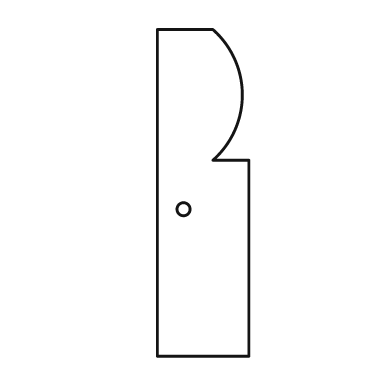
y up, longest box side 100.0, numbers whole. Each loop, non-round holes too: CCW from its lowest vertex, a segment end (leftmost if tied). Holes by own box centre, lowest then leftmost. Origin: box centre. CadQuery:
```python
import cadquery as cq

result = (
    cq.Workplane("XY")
    .moveTo(-14.0, -50.0)
    .lineTo(14.0, -50.0)
    .lineTo(14.0, 10.0)
    .lineTo(3.0, 10.0)
    .threePointArc((12.0, 30.0), (3.0, 50.0))
    .lineTo(-14.0, 50.0)
    .close()
    .moveTo(-6.0, -5.0)
    .circle(2.0)
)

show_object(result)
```